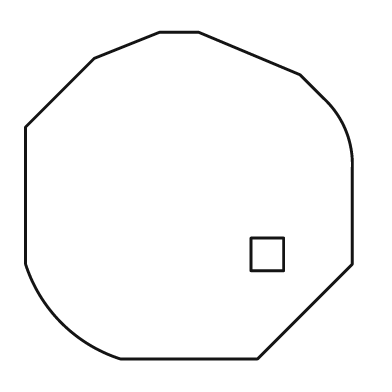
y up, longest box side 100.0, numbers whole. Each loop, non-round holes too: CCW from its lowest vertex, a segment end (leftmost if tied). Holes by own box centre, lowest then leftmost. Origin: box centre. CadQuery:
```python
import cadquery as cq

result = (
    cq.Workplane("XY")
    .moveTo(-21.0, -50.0)
    .lineTo(21.0, -50.0)
    .lineTo(50.0, -21.0)
    .lineTo(50.0, 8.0)
    .threePointArc((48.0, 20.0), (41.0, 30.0))
    .lineTo(34.0, 37.0)
    .lineTo(3.0, 50.0)
    .lineTo(-9.0, 50.0)
    .lineTo(-29.0, 42.0)
    .lineTo(-50.0, 21.0)
    .lineTo(-50.0, -21.0)
    .threePointArc((-39.0, -39.0), (-21.0, -50.0))
    .close()
    .moveTo(19.0, -23.0)
    .lineTo(29.0, -23.0)
    .lineTo(29.0, -13.0)
    .lineTo(19.0, -13.0)
    .close()
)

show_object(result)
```